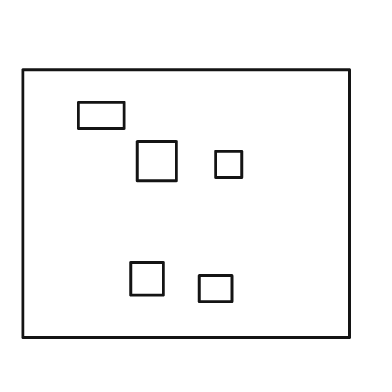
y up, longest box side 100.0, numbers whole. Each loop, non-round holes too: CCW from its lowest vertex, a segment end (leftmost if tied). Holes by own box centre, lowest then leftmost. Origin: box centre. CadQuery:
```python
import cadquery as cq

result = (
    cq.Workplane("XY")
    .moveTo(-50.0, -41.0)
    .lineTo(50.0, -41.0)
    .lineTo(50.0, 41.0)
    .lineTo(-50.0, 41.0)
    .close()
    .moveTo(4.0, -30.0)
    .lineTo(14.0, -30.0)
    .lineTo(14.0, -22.0)
    .lineTo(4.0, -22.0)
    .close()
    .moveTo(-17.0, -28.0)
    .lineTo(-7.0, -28.0)
    .lineTo(-7.0, -18.0)
    .lineTo(-17.0, -18.0)
    .close()
    .moveTo(9.0, 8.0)
    .lineTo(17.0, 8.0)
    .lineTo(17.0, 16.0)
    .lineTo(9.0, 16.0)
    .close()
    .moveTo(-15.0, 7.0)
    .lineTo(-3.0, 7.0)
    .lineTo(-3.0, 19.0)
    .lineTo(-15.0, 19.0)
    .close()
    .moveTo(-33.0, 23.0)
    .lineTo(-19.0, 23.0)
    .lineTo(-19.0, 31.0)
    .lineTo(-33.0, 31.0)
    .close()
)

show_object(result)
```